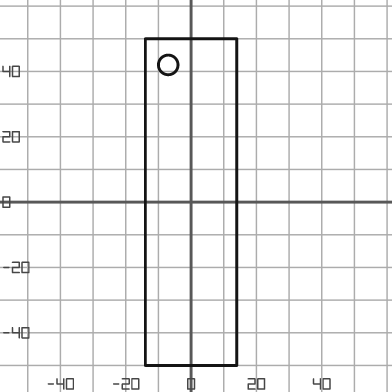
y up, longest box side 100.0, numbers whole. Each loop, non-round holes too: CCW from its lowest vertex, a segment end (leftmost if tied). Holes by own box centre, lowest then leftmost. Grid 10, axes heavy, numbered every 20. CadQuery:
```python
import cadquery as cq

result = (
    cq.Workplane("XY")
    .moveTo(-14.0, -50.0)
    .lineTo(14.0, -50.0)
    .lineTo(14.0, 50.0)
    .lineTo(-14.0, 50.0)
    .close()
    .moveTo(-7.0, 42.0)
    .circle(3.0)
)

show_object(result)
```